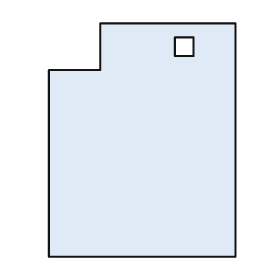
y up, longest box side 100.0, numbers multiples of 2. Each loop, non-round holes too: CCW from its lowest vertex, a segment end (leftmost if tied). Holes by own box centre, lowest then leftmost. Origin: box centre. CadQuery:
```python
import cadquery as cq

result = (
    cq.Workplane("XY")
    .moveTo(-40.0, -50.0)
    .lineTo(40.0, -50.0)
    .lineTo(40.0, 50.0)
    .lineTo(-18.0, 50.0)
    .lineTo(-18.0, 30.0)
    .lineTo(-40.0, 30.0)
    .close()
    .moveTo(14.0, 36.0)
    .lineTo(22.0, 36.0)
    .lineTo(22.0, 44.0)
    .lineTo(14.0, 44.0)
    .close()
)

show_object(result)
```